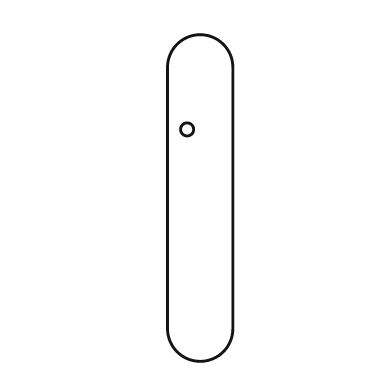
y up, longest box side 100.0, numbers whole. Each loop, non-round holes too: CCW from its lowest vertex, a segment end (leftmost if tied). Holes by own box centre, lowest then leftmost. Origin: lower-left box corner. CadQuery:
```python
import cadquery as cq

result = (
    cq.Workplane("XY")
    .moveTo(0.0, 10.0)
    .threePointArc((10.0, 0.0), (20.0, 10.0))
    .lineTo(20.0, 90.0)
    .threePointArc((10.0, 100.0), (0.0, 90.0))
    .close()
    .moveTo(6.0, 71.0)
    .circle(2.0)
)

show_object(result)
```